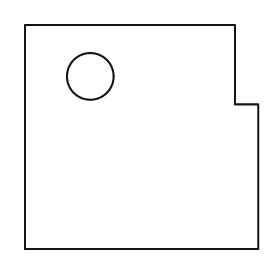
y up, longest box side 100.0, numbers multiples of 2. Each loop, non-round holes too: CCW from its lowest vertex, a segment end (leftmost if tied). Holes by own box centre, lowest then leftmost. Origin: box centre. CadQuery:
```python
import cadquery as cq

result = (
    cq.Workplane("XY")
    .moveTo(-50.0, -48.0)
    .lineTo(50.0, -48.0)
    .lineTo(50.0, 14.0)
    .lineTo(40.0, 14.0)
    .lineTo(40.0, 48.0)
    .lineTo(-50.0, 48.0)
    .close()
    .moveTo(-22.0, 26.0)
    .circle(10.0)
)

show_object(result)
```